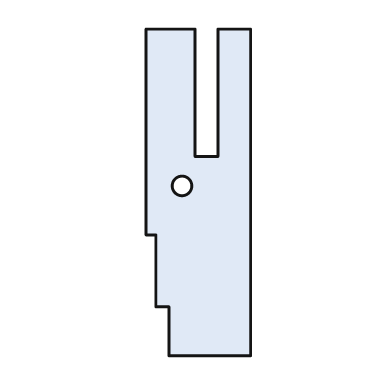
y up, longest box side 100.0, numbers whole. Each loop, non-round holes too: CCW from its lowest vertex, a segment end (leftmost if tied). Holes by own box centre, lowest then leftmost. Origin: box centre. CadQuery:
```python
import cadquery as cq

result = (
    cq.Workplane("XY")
    .moveTo(-9.0, -50.0)
    .lineTo(16.0, -50.0)
    .lineTo(16.0, 50.0)
    .lineTo(6.0, 50.0)
    .lineTo(6.0, 11.0)
    .lineTo(-1.0, 11.0)
    .lineTo(-1.0, 50.0)
    .lineTo(-16.0, 50.0)
    .lineTo(-16.0, -13.0)
    .lineTo(-13.0, -13.0)
    .lineTo(-13.0, -35.0)
    .lineTo(-9.0, -35.0)
    .close()
    .moveTo(-5.0, 2.0)
    .circle(3.0)
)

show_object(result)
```